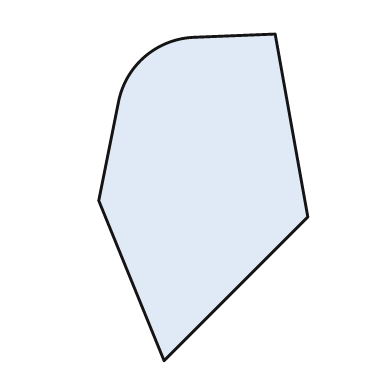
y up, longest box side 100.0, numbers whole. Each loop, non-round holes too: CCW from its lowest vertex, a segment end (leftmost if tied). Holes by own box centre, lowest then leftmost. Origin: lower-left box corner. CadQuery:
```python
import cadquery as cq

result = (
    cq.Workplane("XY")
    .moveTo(20.0, 0.0)
    .lineTo(64.0, 44.0)
    .lineTo(54.0, 100.0)
    .lineTo(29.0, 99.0)
    .threePointArc((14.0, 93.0), (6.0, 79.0))
    .lineTo(0.0, 49.0)
    .close()
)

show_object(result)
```